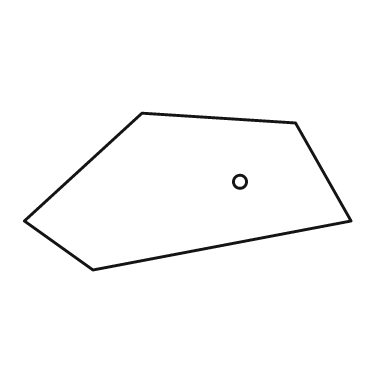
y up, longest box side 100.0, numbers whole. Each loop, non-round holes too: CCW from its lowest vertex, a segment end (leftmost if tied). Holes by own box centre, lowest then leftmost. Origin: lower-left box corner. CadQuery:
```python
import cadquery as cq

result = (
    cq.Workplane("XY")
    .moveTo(21.0, 0.0)
    .lineTo(100.0, 15.0)
    .lineTo(83.0, 45.0)
    .lineTo(36.0, 48.0)
    .lineTo(0.0, 15.0)
    .close()
    .moveTo(66.0, 27.0)
    .circle(2.0)
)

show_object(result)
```